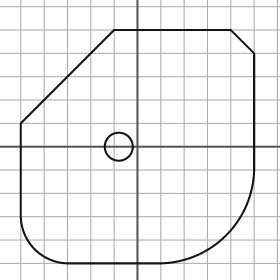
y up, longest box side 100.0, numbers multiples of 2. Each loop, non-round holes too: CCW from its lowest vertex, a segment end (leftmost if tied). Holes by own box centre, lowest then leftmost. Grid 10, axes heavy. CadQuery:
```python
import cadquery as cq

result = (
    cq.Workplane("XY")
    .moveTo(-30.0, -50.0)
    .lineTo(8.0, -50.0)
    .threePointArc((38.0, -38.0), (50.0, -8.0))
    .lineTo(50.0, 40.0)
    .lineTo(40.0, 50.0)
    .lineTo(-10.0, 50.0)
    .lineTo(-50.0, 10.0)
    .lineTo(-50.0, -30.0)
    .threePointArc((-44.0, -44.0), (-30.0, -50.0))
    .close()
    .moveTo(-8.0, 0.0)
    .circle(6.0)
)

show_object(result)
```